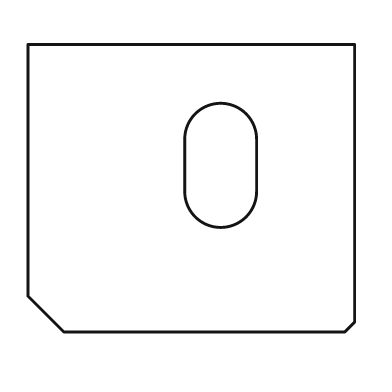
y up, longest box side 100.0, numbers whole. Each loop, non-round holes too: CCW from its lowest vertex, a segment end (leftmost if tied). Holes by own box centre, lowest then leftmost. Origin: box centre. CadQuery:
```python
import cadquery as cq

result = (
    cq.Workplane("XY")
    .moveTo(-39.0, -44.0)
    .lineTo(47.0, -44.0)
    .lineTo(50.0, -41.0)
    .lineTo(50.0, 44.0)
    .lineTo(-50.0, 44.0)
    .lineTo(-50.0, -33.0)
    .close()
    .moveTo(-2.0, -1.0)
    .threePointArc((9.0, -12.0), (20.0, -1.0))
    .lineTo(20.0, 15.0)
    .threePointArc((9.0, 26.0), (-2.0, 15.0))
    .close()
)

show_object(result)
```